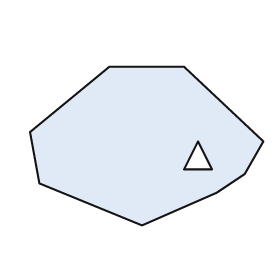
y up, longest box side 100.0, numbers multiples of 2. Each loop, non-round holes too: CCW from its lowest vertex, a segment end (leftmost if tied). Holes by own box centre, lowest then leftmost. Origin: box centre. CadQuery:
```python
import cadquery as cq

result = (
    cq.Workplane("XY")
    .moveTo(-2.0, -34.0)
    .lineTo(30.0, -20.0)
    .lineTo(42.0, -12.0)
    .lineTo(50.0, 2.0)
    .lineTo(16.0, 34.0)
    .lineTo(-16.0, 34.0)
    .lineTo(-50.0, 6.0)
    .lineTo(-46.0, -16.0)
    .close()
    .moveTo(16.0, -10.0)
    .lineTo(28.0, -10.0)
    .lineTo(22.0, 2.0)
    .close()
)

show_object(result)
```